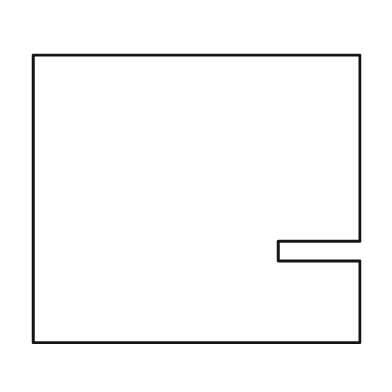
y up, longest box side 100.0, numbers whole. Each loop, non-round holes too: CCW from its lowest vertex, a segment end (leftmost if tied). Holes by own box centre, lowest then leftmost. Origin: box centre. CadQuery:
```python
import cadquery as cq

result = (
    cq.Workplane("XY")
    .moveTo(-50.0, -44.0)
    .lineTo(50.0, -44.0)
    .lineTo(50.0, -19.0)
    .lineTo(25.0, -19.0)
    .lineTo(25.0, -13.0)
    .lineTo(50.0, -13.0)
    .lineTo(50.0, 44.0)
    .lineTo(-50.0, 44.0)
    .close()
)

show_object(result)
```